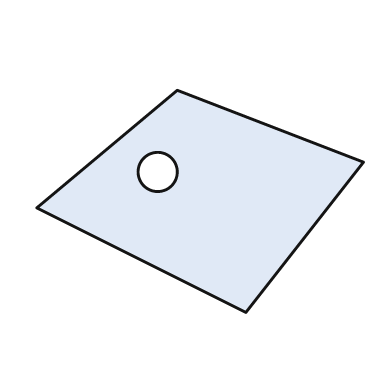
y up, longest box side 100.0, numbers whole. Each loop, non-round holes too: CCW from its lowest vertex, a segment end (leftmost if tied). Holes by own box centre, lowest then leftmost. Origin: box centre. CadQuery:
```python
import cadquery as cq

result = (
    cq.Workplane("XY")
    .moveTo(14.0, -34.0)
    .lineTo(50.0, 12.0)
    .lineTo(-7.0, 34.0)
    .lineTo(-50.0, -2.0)
    .close()
    .moveTo(-13.0, 9.0)
    .circle(6.0)
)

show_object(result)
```